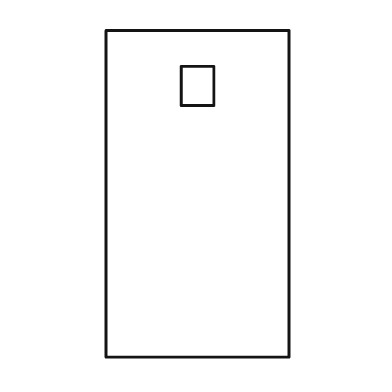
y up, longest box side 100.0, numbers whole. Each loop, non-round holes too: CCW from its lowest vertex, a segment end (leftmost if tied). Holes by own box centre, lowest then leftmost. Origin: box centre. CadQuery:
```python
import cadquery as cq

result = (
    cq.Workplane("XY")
    .moveTo(-28.0, -50.0)
    .lineTo(28.0, -50.0)
    .lineTo(28.0, 50.0)
    .lineTo(-28.0, 50.0)
    .close()
    .moveTo(-5.0, 27.0)
    .lineTo(5.0, 27.0)
    .lineTo(5.0, 39.0)
    .lineTo(-5.0, 39.0)
    .close()
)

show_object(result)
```